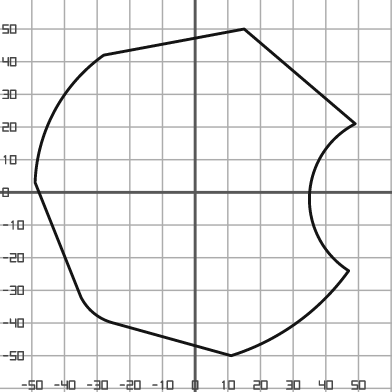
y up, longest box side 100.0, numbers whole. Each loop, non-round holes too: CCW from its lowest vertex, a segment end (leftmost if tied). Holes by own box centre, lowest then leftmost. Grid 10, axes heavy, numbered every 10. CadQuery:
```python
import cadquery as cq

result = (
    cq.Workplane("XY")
    .moveTo(11.0, -50.0)
    .threePointArc((31.0, -40.0), (47.0, -24.0))
    .threePointArc((35.0, -1.0), (49.0, 21.0))
    .lineTo(15.0, 50.0)
    .lineTo(-28.0, 42.0)
    .threePointArc((-43.0, 25.0), (-49.0, 3.0))
    .lineTo(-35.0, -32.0)
    .threePointArc((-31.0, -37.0), (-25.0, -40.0))
    .close()
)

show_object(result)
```